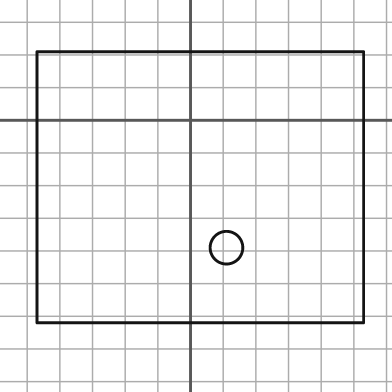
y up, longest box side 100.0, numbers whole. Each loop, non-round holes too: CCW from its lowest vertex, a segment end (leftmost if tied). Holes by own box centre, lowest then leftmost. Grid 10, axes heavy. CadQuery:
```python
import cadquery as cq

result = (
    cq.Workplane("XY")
    .moveTo(-47.0, -62.0)
    .lineTo(53.0, -62.0)
    .lineTo(53.0, 21.0)
    .lineTo(-47.0, 21.0)
    .close()
    .moveTo(11.0, -39.0)
    .circle(5.0)
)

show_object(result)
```